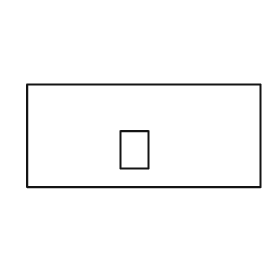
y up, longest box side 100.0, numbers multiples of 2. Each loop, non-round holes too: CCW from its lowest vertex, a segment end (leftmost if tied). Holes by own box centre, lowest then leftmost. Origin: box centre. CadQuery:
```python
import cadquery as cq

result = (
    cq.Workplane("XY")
    .moveTo(-50.0, -22.0)
    .lineTo(50.0, -22.0)
    .lineTo(50.0, 22.0)
    .lineTo(-50.0, 22.0)
    .close()
    .moveTo(-10.0, -14.0)
    .lineTo(2.0, -14.0)
    .lineTo(2.0, 2.0)
    .lineTo(-10.0, 2.0)
    .close()
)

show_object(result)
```